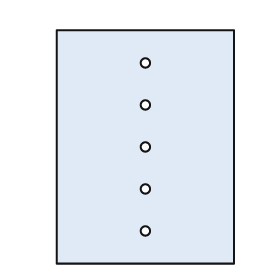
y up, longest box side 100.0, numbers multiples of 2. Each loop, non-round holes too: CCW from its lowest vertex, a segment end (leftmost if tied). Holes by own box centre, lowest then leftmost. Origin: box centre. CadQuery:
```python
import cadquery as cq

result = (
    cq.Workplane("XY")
    .moveTo(-38.0, -50.0)
    .lineTo(38.0, -50.0)
    .lineTo(38.0, 50.0)
    .lineTo(-38.0, 50.0)
    .close()
    .moveTo(0.0, -36.0)
    .circle(2.0)
    .moveTo(0.0, -18.0)
    .circle(2.0)
    .moveTo(0.0, 0.0)
    .circle(2.0)
    .moveTo(0.0, 18.0)
    .circle(2.0)
    .moveTo(0.0, 36.0)
    .circle(2.0)
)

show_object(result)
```